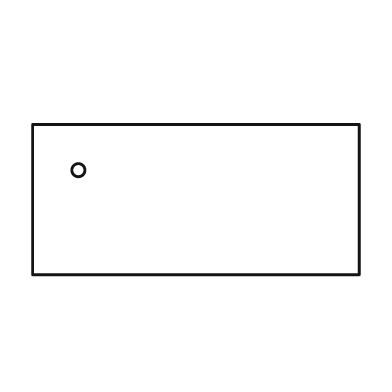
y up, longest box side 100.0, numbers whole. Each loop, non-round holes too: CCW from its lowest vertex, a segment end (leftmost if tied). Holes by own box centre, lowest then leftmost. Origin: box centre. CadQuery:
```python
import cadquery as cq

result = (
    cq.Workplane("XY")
    .moveTo(-50.0, -23.0)
    .lineTo(50.0, -23.0)
    .lineTo(50.0, 23.0)
    .lineTo(-50.0, 23.0)
    .close()
    .moveTo(-36.0, 9.0)
    .circle(2.0)
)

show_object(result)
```